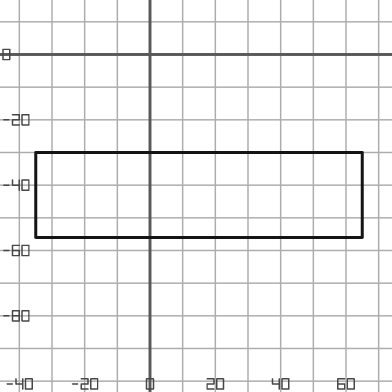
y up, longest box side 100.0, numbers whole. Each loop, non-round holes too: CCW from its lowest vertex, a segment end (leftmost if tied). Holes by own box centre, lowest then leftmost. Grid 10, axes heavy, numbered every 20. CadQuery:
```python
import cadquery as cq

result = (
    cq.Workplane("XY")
    .moveTo(-35.0, -56.0)
    .lineTo(65.0, -56.0)
    .lineTo(65.0, -30.0)
    .lineTo(-35.0, -30.0)
    .close()
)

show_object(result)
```